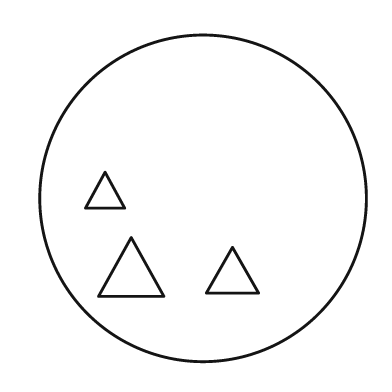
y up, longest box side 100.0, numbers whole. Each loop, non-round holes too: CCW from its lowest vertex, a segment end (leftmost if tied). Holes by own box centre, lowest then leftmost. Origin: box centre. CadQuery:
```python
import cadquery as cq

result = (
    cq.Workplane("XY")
    .moveTo(0.0, 0.0)
    .circle(50.0)
    .moveTo(1.0, -29.0)
    .lineTo(17.0, -29.0)
    .lineTo(9.0, -15.0)
    .close()
    .moveTo(-32.0, -30.0)
    .lineTo(-12.0, -30.0)
    .lineTo(-22.0, -12.0)
    .close()
    .moveTo(-36.0, -3.0)
    .lineTo(-24.0, -3.0)
    .lineTo(-30.0, 8.0)
    .close()
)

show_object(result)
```